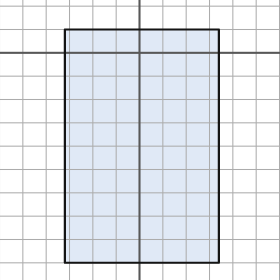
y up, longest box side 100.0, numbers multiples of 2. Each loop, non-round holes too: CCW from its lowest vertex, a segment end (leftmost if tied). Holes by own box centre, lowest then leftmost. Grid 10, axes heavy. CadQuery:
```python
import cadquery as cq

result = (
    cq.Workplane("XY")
    .moveTo(-32.0, -90.0)
    .lineTo(34.0, -90.0)
    .lineTo(34.0, 10.0)
    .lineTo(-32.0, 10.0)
    .close()
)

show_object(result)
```